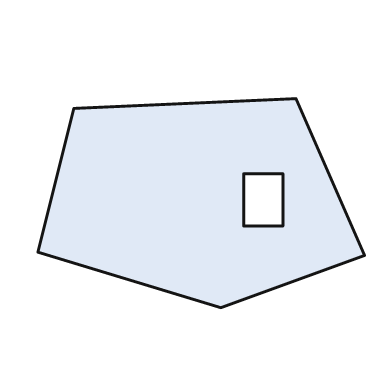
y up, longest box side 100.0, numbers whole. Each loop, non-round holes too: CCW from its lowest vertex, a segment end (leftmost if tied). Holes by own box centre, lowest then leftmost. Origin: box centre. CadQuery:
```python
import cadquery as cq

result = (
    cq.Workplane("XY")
    .moveTo(6.0, -32.0)
    .lineTo(50.0, -16.0)
    .lineTo(29.0, 32.0)
    .lineTo(-39.0, 29.0)
    .lineTo(-50.0, -15.0)
    .close()
    .moveTo(13.0, -7.0)
    .lineTo(25.0, -7.0)
    .lineTo(25.0, 9.0)
    .lineTo(13.0, 9.0)
    .close()
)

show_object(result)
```